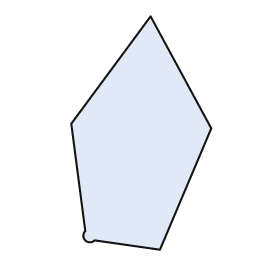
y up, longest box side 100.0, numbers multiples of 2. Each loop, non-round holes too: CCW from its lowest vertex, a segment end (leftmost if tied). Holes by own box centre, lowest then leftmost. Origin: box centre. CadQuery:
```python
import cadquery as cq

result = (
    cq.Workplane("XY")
    .moveTo(8.0, -50.0)
    .lineTo(30.0, 2.0)
    .lineTo(4.0, 50.0)
    .lineTo(-30.0, 4.0)
    .lineTo(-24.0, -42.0)
    .threePointArc((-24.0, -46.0), (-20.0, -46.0))
    .close()
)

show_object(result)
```